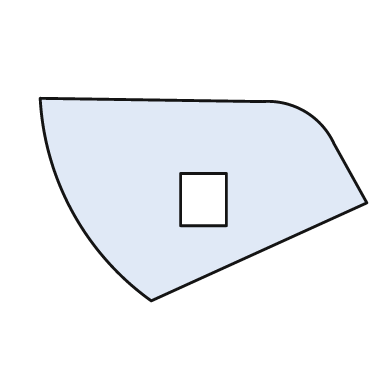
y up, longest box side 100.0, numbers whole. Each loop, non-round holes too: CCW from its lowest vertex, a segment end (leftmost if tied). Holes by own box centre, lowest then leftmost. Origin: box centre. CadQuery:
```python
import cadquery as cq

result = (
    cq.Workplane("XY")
    .moveTo(-16.0, -31.0)
    .lineTo(50.0, -1.0)
    .lineTo(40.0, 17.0)
    .threePointArc((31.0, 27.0), (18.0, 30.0))
    .lineTo(-50.0, 31.0)
    .threePointArc((-40.0, -4.0), (-16.0, -31.0))
    .close()
    .moveTo(-7.0, -8.0)
    .lineTo(7.0, -8.0)
    .lineTo(7.0, 8.0)
    .lineTo(-7.0, 8.0)
    .close()
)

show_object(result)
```